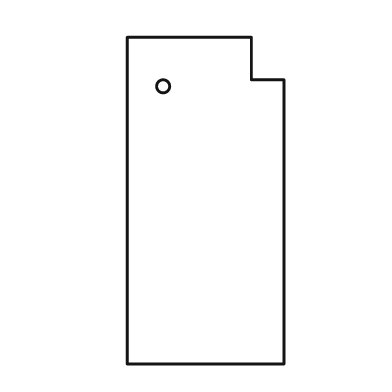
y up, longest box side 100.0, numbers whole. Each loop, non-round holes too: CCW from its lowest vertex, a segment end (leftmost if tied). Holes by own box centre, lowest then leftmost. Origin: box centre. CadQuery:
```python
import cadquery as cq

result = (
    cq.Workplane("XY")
    .moveTo(-24.0, -50.0)
    .lineTo(24.0, -50.0)
    .lineTo(24.0, 37.0)
    .lineTo(14.0, 37.0)
    .lineTo(14.0, 50.0)
    .lineTo(-24.0, 50.0)
    .close()
    .moveTo(-13.0, 35.0)
    .circle(2.0)
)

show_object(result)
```